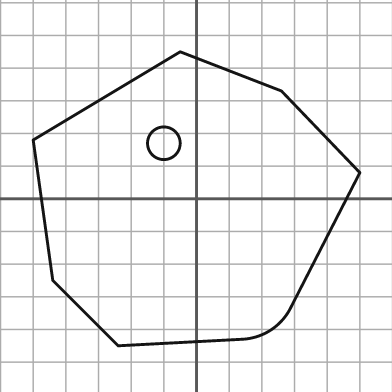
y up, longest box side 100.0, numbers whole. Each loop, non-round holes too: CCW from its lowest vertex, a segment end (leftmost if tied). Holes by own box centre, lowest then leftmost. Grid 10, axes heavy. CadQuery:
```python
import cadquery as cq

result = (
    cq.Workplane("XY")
    .moveTo(-24.0, -45.0)
    .lineTo(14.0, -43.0)
    .threePointArc((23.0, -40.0), (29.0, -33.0))
    .lineTo(50.0, 8.0)
    .lineTo(26.0, 33.0)
    .lineTo(-5.0, 45.0)
    .lineTo(-50.0, 18.0)
    .lineTo(-44.0, -25.0)
    .close()
    .moveTo(-10.0, 17.0)
    .circle(5.0)
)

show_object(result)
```